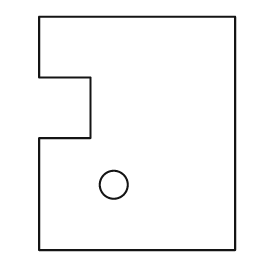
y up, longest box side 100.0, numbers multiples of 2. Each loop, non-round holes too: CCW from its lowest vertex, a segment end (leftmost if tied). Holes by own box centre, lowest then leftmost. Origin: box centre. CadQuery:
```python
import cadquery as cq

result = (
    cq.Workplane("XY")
    .moveTo(-42.0, -50.0)
    .lineTo(42.0, -50.0)
    .lineTo(42.0, 50.0)
    .lineTo(-42.0, 50.0)
    .lineTo(-42.0, 24.0)
    .lineTo(-20.0, 24.0)
    .lineTo(-20.0, -2.0)
    .lineTo(-42.0, -2.0)
    .close()
    .moveTo(-10.0, -22.0)
    .circle(6.0)
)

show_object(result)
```